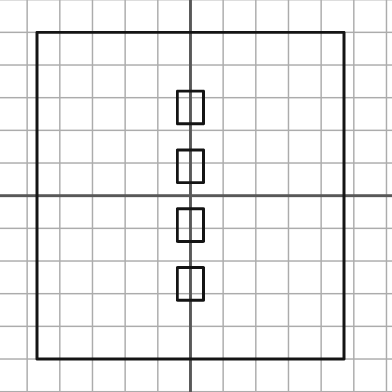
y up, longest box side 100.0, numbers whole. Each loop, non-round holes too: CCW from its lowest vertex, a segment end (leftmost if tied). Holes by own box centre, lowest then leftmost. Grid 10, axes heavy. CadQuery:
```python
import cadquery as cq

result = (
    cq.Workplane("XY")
    .moveTo(-47.0, -50.0)
    .lineTo(47.0, -50.0)
    .lineTo(47.0, 50.0)
    .lineTo(-47.0, 50.0)
    .close()
    .moveTo(-4.0, -32.0)
    .lineTo(4.0, -32.0)
    .lineTo(4.0, -22.0)
    .lineTo(-4.0, -22.0)
    .close()
    .moveTo(-4.0, -14.0)
    .lineTo(4.0, -14.0)
    .lineTo(4.0, -4.0)
    .lineTo(-4.0, -4.0)
    .close()
    .moveTo(-4.0, 4.0)
    .lineTo(4.0, 4.0)
    .lineTo(4.0, 14.0)
    .lineTo(-4.0, 14.0)
    .close()
    .moveTo(-4.0, 22.0)
    .lineTo(4.0, 22.0)
    .lineTo(4.0, 32.0)
    .lineTo(-4.0, 32.0)
    .close()
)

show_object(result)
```